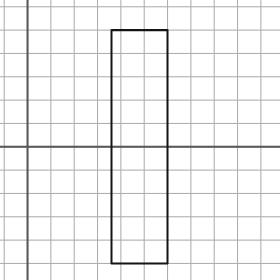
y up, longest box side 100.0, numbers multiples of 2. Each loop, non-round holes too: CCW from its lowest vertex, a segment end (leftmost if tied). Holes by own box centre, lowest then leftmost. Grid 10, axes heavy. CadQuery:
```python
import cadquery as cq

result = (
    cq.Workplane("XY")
    .moveTo(36.0, -50.0)
    .lineTo(60.0, -50.0)
    .lineTo(60.0, 50.0)
    .lineTo(36.0, 50.0)
    .close()
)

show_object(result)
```